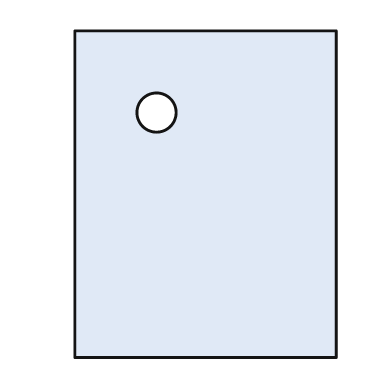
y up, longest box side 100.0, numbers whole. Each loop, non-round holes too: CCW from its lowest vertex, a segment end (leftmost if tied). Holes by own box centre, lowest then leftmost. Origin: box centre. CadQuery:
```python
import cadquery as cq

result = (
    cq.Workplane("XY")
    .moveTo(-40.0, -50.0)
    .lineTo(40.0, -50.0)
    .lineTo(40.0, 50.0)
    .lineTo(-40.0, 50.0)
    .close()
    .moveTo(-15.0, 25.0)
    .circle(6.0)
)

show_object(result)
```